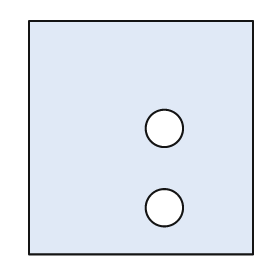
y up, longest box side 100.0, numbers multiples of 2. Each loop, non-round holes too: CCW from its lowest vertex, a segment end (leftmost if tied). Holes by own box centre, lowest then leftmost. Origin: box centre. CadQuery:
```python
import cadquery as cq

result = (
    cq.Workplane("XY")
    .moveTo(-48.0, -50.0)
    .lineTo(48.0, -50.0)
    .lineTo(48.0, 50.0)
    .lineTo(-48.0, 50.0)
    .close()
    .moveTo(10.0, -30.0)
    .circle(8.0)
    .moveTo(10.0, 4.0)
    .circle(8.0)
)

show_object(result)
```